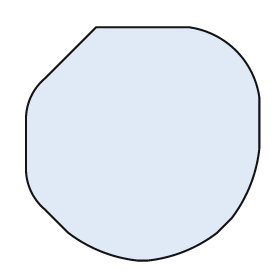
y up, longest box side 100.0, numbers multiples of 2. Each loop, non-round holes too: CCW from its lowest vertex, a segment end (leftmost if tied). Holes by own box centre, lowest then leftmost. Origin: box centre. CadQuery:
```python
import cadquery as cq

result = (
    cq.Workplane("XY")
    .moveTo(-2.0, -50.0)
    .lineTo(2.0, -50.0)
    .threePointArc((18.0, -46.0), (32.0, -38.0))
    .lineTo(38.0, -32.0)
    .threePointArc((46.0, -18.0), (50.0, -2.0))
    .lineTo(50.0, 20.0)
    .threePointArc((40.0, 40.0), (20.0, 50.0))
    .lineTo(-20.0, 50.0)
    .lineTo(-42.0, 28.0)
    .threePointArc((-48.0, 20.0), (-50.0, 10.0))
    .lineTo(-50.0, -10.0)
    .threePointArc((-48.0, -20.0), (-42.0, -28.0))
    .lineTo(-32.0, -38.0)
    .threePointArc((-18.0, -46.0), (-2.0, -50.0))
    .close()
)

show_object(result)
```